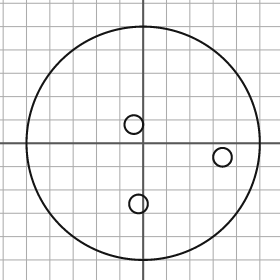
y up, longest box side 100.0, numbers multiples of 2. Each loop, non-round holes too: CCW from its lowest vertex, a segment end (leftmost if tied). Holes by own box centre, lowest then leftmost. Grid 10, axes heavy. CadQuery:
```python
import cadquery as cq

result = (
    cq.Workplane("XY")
    .moveTo(0.0, 0.0)
    .circle(50.0)
    .moveTo(-2.0, -26.0)
    .circle(4.0)
    .moveTo(34.0, -6.0)
    .circle(4.0)
    .moveTo(-4.0, 8.0)
    .circle(4.0)
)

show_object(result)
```